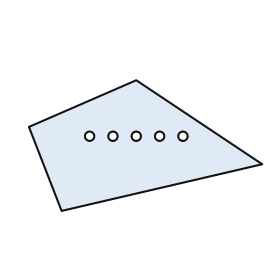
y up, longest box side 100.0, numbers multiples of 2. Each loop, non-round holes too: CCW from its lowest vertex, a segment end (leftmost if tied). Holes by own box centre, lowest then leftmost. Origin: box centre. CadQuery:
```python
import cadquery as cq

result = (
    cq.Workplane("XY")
    .moveTo(-36.0, -28.0)
    .lineTo(50.0, -8.0)
    .lineTo(-4.0, 28.0)
    .lineTo(-50.0, 8.0)
    .close()
    .moveTo(-24.0, 4.0)
    .circle(2.0)
    .moveTo(-14.0, 4.0)
    .circle(2.0)
    .moveTo(-4.0, 4.0)
    .circle(2.0)
    .moveTo(6.0, 4.0)
    .circle(2.0)
    .moveTo(16.0, 4.0)
    .circle(2.0)
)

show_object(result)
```